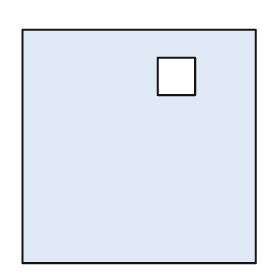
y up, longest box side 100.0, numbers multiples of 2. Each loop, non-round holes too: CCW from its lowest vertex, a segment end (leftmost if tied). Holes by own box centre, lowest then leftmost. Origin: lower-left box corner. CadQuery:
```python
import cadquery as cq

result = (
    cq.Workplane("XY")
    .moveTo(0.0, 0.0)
    .lineTo(100.0, 0.0)
    .lineTo(100.0, 100.0)
    .lineTo(0.0, 100.0)
    .close()
    .moveTo(58.0, 72.0)
    .lineTo(74.0, 72.0)
    .lineTo(74.0, 88.0)
    .lineTo(58.0, 88.0)
    .close()
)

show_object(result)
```